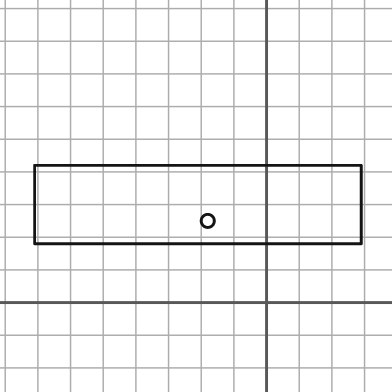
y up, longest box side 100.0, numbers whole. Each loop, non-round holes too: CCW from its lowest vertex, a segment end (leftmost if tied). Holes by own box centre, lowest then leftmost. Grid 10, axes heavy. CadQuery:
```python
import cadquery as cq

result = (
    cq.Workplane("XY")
    .moveTo(-71.0, 18.0)
    .lineTo(29.0, 18.0)
    .lineTo(29.0, 42.0)
    .lineTo(-71.0, 42.0)
    .close()
    .moveTo(-18.0, 25.0)
    .circle(2.0)
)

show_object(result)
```